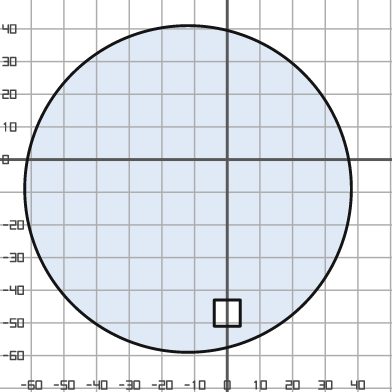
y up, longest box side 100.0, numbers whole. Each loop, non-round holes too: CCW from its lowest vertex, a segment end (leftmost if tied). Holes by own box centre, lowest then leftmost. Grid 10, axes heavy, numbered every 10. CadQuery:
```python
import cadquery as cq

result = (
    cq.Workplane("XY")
    .moveTo(-12.0, -9.0)
    .circle(50.0)
    .moveTo(-4.0, -51.0)
    .lineTo(4.0, -51.0)
    .lineTo(4.0, -43.0)
    .lineTo(-4.0, -43.0)
    .close()
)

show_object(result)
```